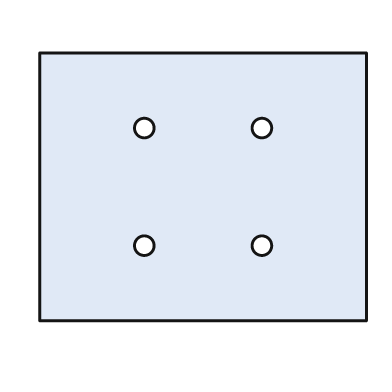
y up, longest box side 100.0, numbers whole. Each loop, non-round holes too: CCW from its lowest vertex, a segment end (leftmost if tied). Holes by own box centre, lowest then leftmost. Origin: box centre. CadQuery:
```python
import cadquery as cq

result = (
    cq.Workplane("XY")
    .moveTo(-50.0, -41.0)
    .lineTo(50.0, -41.0)
    .lineTo(50.0, 41.0)
    .lineTo(-50.0, 41.0)
    .close()
    .moveTo(-18.0, -18.0)
    .circle(3.0)
    .moveTo(18.0, -18.0)
    .circle(3.0)
    .moveTo(-18.0, 18.0)
    .circle(3.0)
    .moveTo(18.0, 18.0)
    .circle(3.0)
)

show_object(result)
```